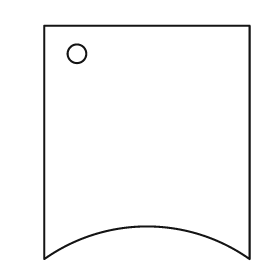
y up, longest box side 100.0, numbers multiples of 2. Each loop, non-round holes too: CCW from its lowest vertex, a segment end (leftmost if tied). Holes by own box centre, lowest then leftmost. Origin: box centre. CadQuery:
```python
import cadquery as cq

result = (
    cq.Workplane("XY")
    .moveTo(-44.0, -50.0)
    .threePointArc((0.0, -36.0), (44.0, -50.0))
    .lineTo(44.0, 50.0)
    .lineTo(-44.0, 50.0)
    .close()
    .moveTo(-30.0, 38.0)
    .circle(4.0)
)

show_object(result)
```